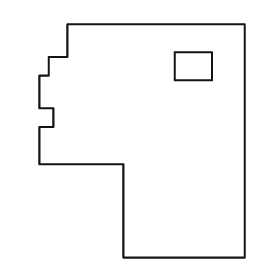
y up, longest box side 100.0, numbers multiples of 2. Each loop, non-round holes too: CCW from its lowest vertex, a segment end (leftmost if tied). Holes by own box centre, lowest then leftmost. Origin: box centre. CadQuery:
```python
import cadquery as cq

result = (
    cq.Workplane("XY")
    .moveTo(-8.0, -50.0)
    .lineTo(44.0, -50.0)
    .lineTo(44.0, 50.0)
    .lineTo(-32.0, 50.0)
    .lineTo(-32.0, 36.0)
    .lineTo(-40.0, 36.0)
    .lineTo(-40.0, 28.0)
    .lineTo(-44.0, 28.0)
    .lineTo(-44.0, 14.0)
    .lineTo(-38.0, 14.0)
    .lineTo(-38.0, 6.0)
    .lineTo(-44.0, 6.0)
    .lineTo(-44.0, -10.0)
    .lineTo(-8.0, -10.0)
    .close()
    .moveTo(14.0, 26.0)
    .lineTo(30.0, 26.0)
    .lineTo(30.0, 38.0)
    .lineTo(14.0, 38.0)
    .close()
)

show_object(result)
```